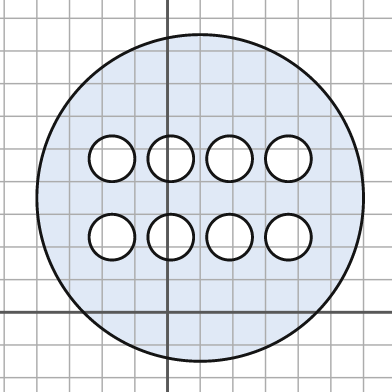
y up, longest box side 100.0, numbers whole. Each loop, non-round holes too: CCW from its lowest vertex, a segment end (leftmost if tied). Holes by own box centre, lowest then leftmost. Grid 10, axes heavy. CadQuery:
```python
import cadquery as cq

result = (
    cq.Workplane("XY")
    .moveTo(10.0, 35.0)
    .circle(50.0)
    .moveTo(-17.0, 23.0)
    .circle(7.0)
    .moveTo(1.0, 23.0)
    .circle(7.0)
    .moveTo(19.0, 23.0)
    .circle(7.0)
    .moveTo(37.0, 23.0)
    .circle(7.0)
    .moveTo(-17.0, 47.0)
    .circle(7.0)
    .moveTo(1.0, 47.0)
    .circle(7.0)
    .moveTo(19.0, 47.0)
    .circle(7.0)
    .moveTo(37.0, 47.0)
    .circle(7.0)
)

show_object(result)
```